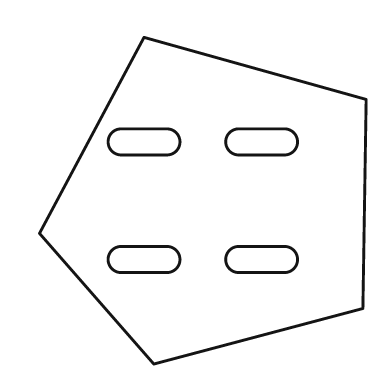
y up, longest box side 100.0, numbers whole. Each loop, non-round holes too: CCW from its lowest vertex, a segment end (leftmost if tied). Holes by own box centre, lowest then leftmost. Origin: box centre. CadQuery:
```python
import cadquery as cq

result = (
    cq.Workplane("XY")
    .moveTo(-15.0, -50.0)
    .lineTo(49.0, -33.0)
    .lineTo(50.0, 31.0)
    .lineTo(-18.0, 50.0)
    .lineTo(-50.0, -10.0)
    .close()
    .moveTo(-25.0, -22.0)
    .lineTo(-11.0, -22.0)
    .threePointArc((-7.0, -18.0), (-11.0, -14.0))
    .lineTo(-25.0, -14.0)
    .threePointArc((-29.0, -18.0), (-25.0, -22.0))
    .close()
    .moveTo(11.0, -22.0)
    .lineTo(25.0, -22.0)
    .threePointArc((29.0, -18.0), (25.0, -14.0))
    .lineTo(11.0, -14.0)
    .threePointArc((7.0, -18.0), (11.0, -22.0))
    .close()
    .moveTo(-25.0, 14.0)
    .lineTo(-11.0, 14.0)
    .threePointArc((-7.0, 18.0), (-11.0, 22.0))
    .lineTo(-25.0, 22.0)
    .threePointArc((-29.0, 18.0), (-25.0, 14.0))
    .close()
    .moveTo(11.0, 14.0)
    .lineTo(25.0, 14.0)
    .threePointArc((29.0, 18.0), (25.0, 22.0))
    .lineTo(11.0, 22.0)
    .threePointArc((7.0, 18.0), (11.0, 14.0))
    .close()
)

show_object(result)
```